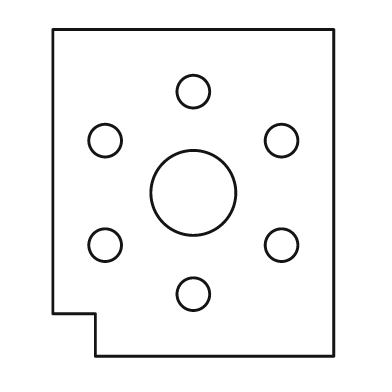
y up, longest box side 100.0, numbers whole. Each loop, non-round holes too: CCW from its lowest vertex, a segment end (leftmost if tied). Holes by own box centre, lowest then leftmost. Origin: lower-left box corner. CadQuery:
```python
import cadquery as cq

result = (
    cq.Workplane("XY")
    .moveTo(13.0, 0.0)
    .lineTo(86.0, 0.0)
    .lineTo(86.0, 100.0)
    .lineTo(0.0, 100.0)
    .lineTo(0.0, 13.0)
    .lineTo(13.0, 13.0)
    .close()
    .moveTo(43.0, 19.0)
    .circle(5.0)
    .moveTo(16.0, 34.0)
    .circle(5.0)
    .moveTo(70.0, 34.0)
    .circle(5.0)
    .moveTo(43.0, 50.0)
    .circle(13.0)
    .moveTo(16.0, 66.0)
    .circle(5.0)
    .moveTo(70.0, 66.0)
    .circle(5.0)
    .moveTo(43.0, 81.0)
    .circle(5.0)
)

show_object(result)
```